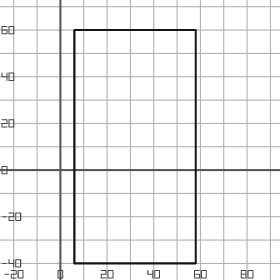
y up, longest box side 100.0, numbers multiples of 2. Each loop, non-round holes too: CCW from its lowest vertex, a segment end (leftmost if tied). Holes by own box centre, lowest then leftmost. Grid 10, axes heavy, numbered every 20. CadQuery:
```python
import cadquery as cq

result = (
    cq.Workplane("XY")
    .moveTo(6.0, -40.0)
    .lineTo(58.0, -40.0)
    .lineTo(58.0, 60.0)
    .lineTo(6.0, 60.0)
    .close()
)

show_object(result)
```